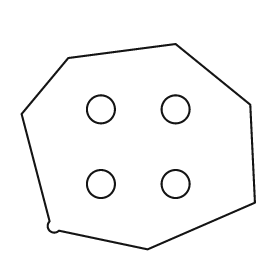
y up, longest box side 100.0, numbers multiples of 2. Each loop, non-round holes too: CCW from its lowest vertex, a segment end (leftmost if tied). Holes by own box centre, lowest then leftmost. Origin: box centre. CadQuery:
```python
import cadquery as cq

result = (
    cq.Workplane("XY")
    .moveTo(4.0, -44.0)
    .lineTo(50.0, -24.0)
    .lineTo(48.0, 18.0)
    .lineTo(16.0, 44.0)
    .lineTo(-30.0, 38.0)
    .lineTo(-50.0, 14.0)
    .lineTo(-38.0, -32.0)
    .threePointArc((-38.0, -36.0), (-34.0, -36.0))
    .close()
    .moveTo(-16.0, -16.0)
    .circle(6.0)
    .moveTo(16.0, -16.0)
    .circle(6.0)
    .moveTo(-16.0, 16.0)
    .circle(6.0)
    .moveTo(16.0, 16.0)
    .circle(6.0)
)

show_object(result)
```